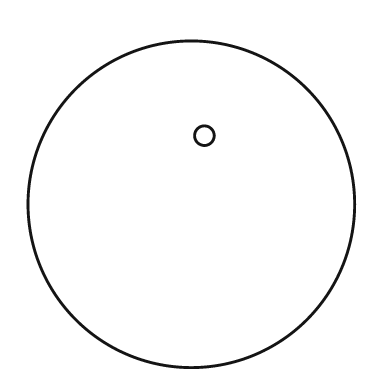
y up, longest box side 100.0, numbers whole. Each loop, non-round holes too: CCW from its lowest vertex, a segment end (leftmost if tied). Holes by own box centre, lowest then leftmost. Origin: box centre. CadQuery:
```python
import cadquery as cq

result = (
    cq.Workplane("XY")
    .moveTo(0.0, 0.0)
    .circle(50.0)
    .moveTo(4.0, 21.0)
    .circle(3.0)
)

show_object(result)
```